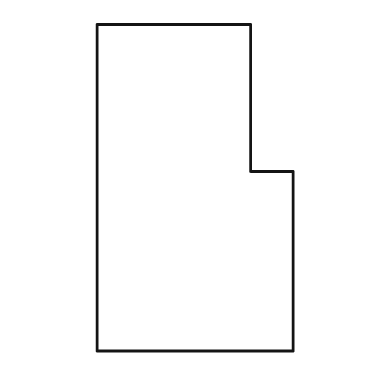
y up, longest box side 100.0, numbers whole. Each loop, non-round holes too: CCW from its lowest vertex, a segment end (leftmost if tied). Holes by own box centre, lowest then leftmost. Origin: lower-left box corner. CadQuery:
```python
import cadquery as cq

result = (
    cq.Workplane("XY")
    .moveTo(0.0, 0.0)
    .lineTo(60.0, 0.0)
    .lineTo(60.0, 55.0)
    .lineTo(47.0, 55.0)
    .lineTo(47.0, 100.0)
    .lineTo(0.0, 100.0)
    .close()
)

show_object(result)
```